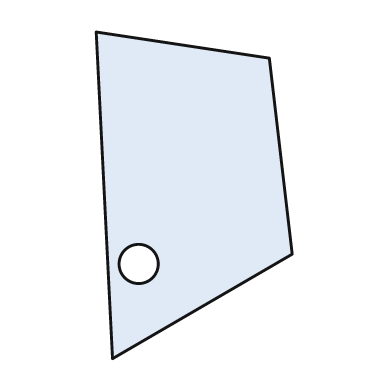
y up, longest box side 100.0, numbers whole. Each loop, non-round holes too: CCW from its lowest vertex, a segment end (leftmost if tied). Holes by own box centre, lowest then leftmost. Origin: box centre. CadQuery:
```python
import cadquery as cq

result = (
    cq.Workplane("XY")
    .moveTo(-25.0, -50.0)
    .lineTo(30.0, -18.0)
    .lineTo(23.0, 42.0)
    .lineTo(-30.0, 50.0)
    .close()
    .moveTo(-17.0, -21.0)
    .circle(6.0)
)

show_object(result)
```